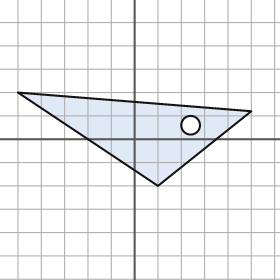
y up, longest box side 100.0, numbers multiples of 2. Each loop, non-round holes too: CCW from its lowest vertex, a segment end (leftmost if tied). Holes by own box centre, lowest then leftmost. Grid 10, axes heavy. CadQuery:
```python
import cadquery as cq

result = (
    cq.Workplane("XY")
    .moveTo(10.0, -20.0)
    .lineTo(50.0, 12.0)
    .lineTo(-50.0, 20.0)
    .close()
    .moveTo(24.0, 6.0)
    .circle(4.0)
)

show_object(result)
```